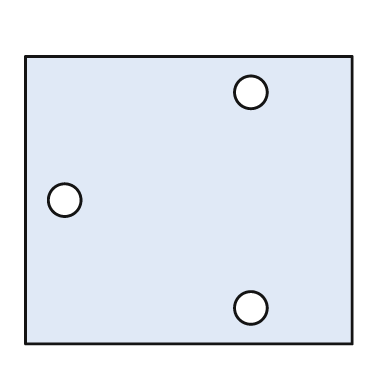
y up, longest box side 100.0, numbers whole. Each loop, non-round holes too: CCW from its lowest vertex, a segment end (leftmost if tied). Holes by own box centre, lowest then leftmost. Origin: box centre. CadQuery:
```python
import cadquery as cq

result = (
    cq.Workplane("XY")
    .moveTo(-50.0, -44.0)
    .lineTo(50.0, -44.0)
    .lineTo(50.0, 44.0)
    .lineTo(-50.0, 44.0)
    .close()
    .moveTo(19.0, -33.0)
    .circle(5.0)
    .moveTo(-38.0, 0.0)
    .circle(5.0)
    .moveTo(19.0, 33.0)
    .circle(5.0)
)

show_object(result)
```